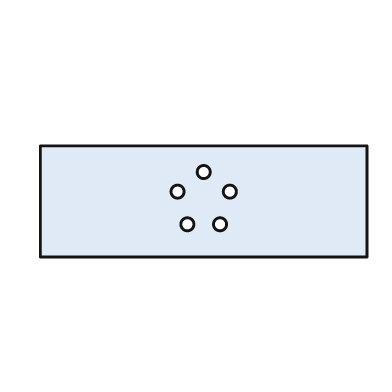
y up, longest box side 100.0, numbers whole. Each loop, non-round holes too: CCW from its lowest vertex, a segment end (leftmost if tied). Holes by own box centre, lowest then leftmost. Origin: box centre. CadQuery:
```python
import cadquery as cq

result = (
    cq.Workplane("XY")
    .moveTo(-50.0, -17.0)
    .lineTo(50.0, -17.0)
    .lineTo(50.0, 17.0)
    .lineTo(-50.0, 17.0)
    .close()
    .moveTo(-5.0, -7.0)
    .circle(2.0)
    .moveTo(5.0, -7.0)
    .circle(2.0)
    .moveTo(-8.0, 3.0)
    .circle(2.0)
    .moveTo(8.0, 3.0)
    .circle(2.0)
    .moveTo(0.0, 9.0)
    .circle(2.0)
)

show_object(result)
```